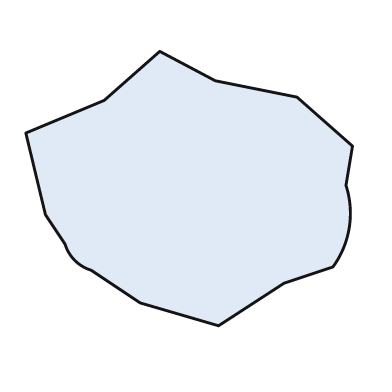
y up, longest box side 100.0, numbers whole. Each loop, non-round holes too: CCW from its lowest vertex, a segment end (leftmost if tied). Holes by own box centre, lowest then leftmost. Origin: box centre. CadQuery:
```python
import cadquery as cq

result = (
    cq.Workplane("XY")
    .moveTo(9.0, -42.0)
    .lineTo(29.0, -29.0)
    .lineTo(44.0, -24.0)
    .threePointArc((49.0, -12.0), (48.0, 1.0))
    .lineTo(50.0, 13.0)
    .lineTo(33.0, 28.0)
    .lineTo(8.0, 33.0)
    .lineTo(-9.0, 42.0)
    .lineTo(-26.0, 27.0)
    .lineTo(-50.0, 17.0)
    .lineTo(-44.0, -8.0)
    .lineTo(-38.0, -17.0)
    .threePointArc((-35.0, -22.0), (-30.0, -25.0))
    .lineTo(-15.0, -35.0)
    .close()
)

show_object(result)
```